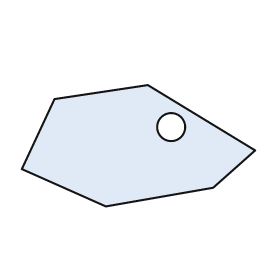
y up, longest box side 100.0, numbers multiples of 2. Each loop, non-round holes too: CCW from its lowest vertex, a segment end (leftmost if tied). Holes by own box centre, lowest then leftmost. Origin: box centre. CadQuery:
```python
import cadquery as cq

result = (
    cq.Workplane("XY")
    .moveTo(-14.0, -26.0)
    .lineTo(32.0, -18.0)
    .lineTo(50.0, -2.0)
    .lineTo(4.0, 26.0)
    .lineTo(-36.0, 20.0)
    .lineTo(-50.0, -10.0)
    .close()
    .moveTo(14.0, 8.0)
    .circle(6.0)
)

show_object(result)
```